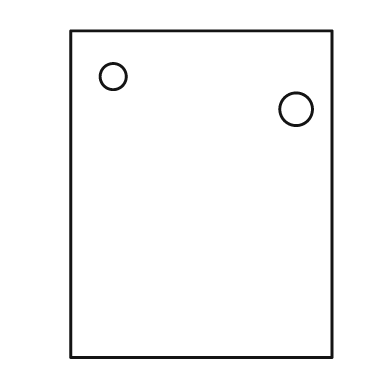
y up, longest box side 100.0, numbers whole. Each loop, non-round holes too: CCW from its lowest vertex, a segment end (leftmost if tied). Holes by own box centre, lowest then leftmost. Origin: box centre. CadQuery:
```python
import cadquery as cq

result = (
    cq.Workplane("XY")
    .moveTo(-40.0, -50.0)
    .lineTo(40.0, -50.0)
    .lineTo(40.0, 50.0)
    .lineTo(-40.0, 50.0)
    .close()
    .moveTo(29.0, 26.0)
    .circle(5.0)
    .moveTo(-27.0, 36.0)
    .circle(4.0)
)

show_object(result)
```